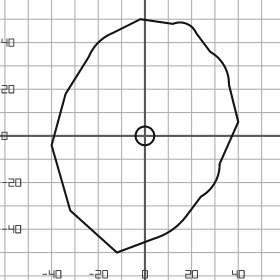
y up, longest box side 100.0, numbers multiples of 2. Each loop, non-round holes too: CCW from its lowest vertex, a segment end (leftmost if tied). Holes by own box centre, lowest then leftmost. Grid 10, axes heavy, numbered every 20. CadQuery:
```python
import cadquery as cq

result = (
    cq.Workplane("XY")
    .moveTo(-12.0, -50.0)
    .lineTo(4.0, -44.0)
    .threePointArc((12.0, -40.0), (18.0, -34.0))
    .lineTo(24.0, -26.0)
    .threePointArc((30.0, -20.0), (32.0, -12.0))
    .lineTo(40.0, 6.0)
    .lineTo(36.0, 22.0)
    .threePointArc((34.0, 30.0), (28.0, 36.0))
    .lineTo(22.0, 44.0)
    .threePointArc((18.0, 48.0), (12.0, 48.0))
    .lineTo(-2.0, 50.0)
    .lineTo(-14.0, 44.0)
    .threePointArc((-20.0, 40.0), (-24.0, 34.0))
    .lineTo(-34.0, 18.0)
    .lineTo(-40.0, -4.0)
    .lineTo(-32.0, -32.0)
    .close()
    .moveTo(0.0, 0.0)
    .circle(4.0)
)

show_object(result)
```